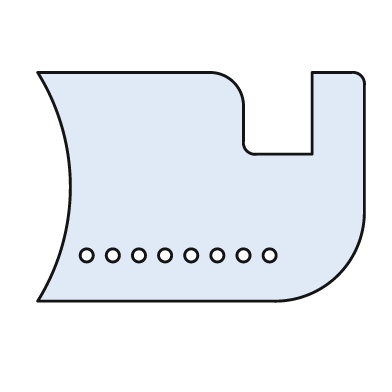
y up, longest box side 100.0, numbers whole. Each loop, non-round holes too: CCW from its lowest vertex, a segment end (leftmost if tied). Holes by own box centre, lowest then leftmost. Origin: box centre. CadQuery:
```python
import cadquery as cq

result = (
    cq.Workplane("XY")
    .moveTo(-50.0, -35.0)
    .lineTo(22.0, -35.0)
    .threePointArc((42.0, -27.0), (50.0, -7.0))
    .lineTo(50.0, 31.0)
    .threePointArc((49.0, 34.0), (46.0, 35.0))
    .lineTo(34.0, 35.0)
    .lineTo(34.0, 10.0)
    .lineTo(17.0, 10.0)
    .threePointArc((14.0, 11.0), (13.0, 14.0))
    .lineTo(13.0, 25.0)
    .threePointArc((10.0, 32.0), (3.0, 35.0))
    .lineTo(-50.0, 35.0)
    .threePointArc((-40.0, 0.0), (-50.0, -35.0))
    .close()
    .moveTo(-35.0, -21.0)
    .circle(2.0)
    .moveTo(-27.0, -21.0)
    .circle(2.0)
    .moveTo(-19.0, -21.0)
    .circle(2.0)
    .moveTo(-11.0, -21.0)
    .circle(2.0)
    .moveTo(-3.0, -21.0)
    .circle(2.0)
    .moveTo(5.0, -21.0)
    .circle(2.0)
    .moveTo(13.0, -21.0)
    .circle(2.0)
    .moveTo(21.0, -21.0)
    .circle(2.0)
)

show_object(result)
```